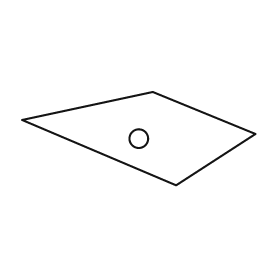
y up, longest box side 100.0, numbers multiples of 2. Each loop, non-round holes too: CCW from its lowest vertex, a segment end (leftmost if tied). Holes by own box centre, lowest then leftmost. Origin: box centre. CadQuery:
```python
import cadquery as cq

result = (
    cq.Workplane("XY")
    .moveTo(16.0, -20.0)
    .lineTo(50.0, 2.0)
    .lineTo(6.0, 20.0)
    .lineTo(-50.0, 8.0)
    .close()
    .moveTo(0.0, 0.0)
    .circle(4.0)
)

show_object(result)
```